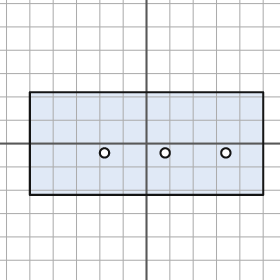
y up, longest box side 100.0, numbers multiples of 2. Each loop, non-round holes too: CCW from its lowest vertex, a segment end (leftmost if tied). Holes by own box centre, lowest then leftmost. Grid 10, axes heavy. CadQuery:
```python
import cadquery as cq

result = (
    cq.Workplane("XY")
    .moveTo(-50.0, -22.0)
    .lineTo(50.0, -22.0)
    .lineTo(50.0, 22.0)
    .lineTo(-50.0, 22.0)
    .close()
    .moveTo(-18.0, -4.0)
    .circle(2.0)
    .moveTo(8.0, -4.0)
    .circle(2.0)
    .moveTo(34.0, -4.0)
    .circle(2.0)
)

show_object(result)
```